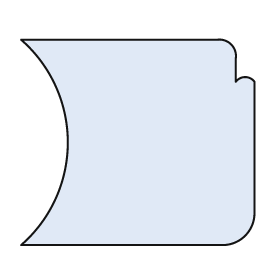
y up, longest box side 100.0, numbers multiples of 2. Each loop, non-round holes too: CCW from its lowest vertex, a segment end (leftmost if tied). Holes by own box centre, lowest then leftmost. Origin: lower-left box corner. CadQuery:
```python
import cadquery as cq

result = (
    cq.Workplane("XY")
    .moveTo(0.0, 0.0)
    .lineTo(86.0, 0.0)
    .threePointArc((96.0, 4.0), (100.0, 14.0))
    .lineTo(100.0, 70.0)
    .threePointArc((96.0, 72.0), (92.0, 70.0))
    .lineTo(92.0, 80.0)
    .threePointArc((90.0, 86.0), (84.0, 88.0))
    .lineTo(0.0, 88.0)
    .threePointArc((20.0, 44.0), (0.0, 0.0))
    .close()
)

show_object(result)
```